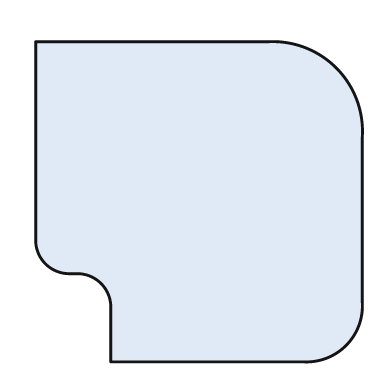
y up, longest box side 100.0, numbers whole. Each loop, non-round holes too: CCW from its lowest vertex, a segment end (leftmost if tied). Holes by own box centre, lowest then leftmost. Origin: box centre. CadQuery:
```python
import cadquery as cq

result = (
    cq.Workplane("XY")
    .moveTo(-27.0, -49.0)
    .lineTo(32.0, -49.0)
    .threePointArc((45.0, -44.0), (50.0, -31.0))
    .lineTo(50.0, 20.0)
    .threePointArc((42.0, 41.0), (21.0, 49.0))
    .lineTo(-50.0, 49.0)
    .lineTo(-50.0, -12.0)
    .threePointArc((-47.0, -19.0), (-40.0, -22.0))
    .lineTo(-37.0, -22.0)
    .threePointArc((-30.0, -25.0), (-27.0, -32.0))
    .close()
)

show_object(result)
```